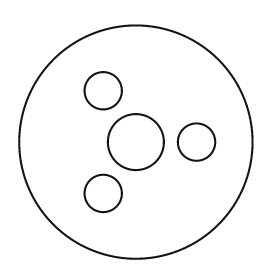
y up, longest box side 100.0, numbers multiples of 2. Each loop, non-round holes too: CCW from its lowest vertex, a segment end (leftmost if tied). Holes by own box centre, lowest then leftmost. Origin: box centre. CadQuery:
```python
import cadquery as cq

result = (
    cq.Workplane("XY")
    .moveTo(0.0, 0.0)
    .circle(50.0)
    .moveTo(-14.0, -22.0)
    .circle(8.0)
    .moveTo(0.0, 0.0)
    .circle(12.0)
    .moveTo(26.0, 0.0)
    .circle(8.0)
    .moveTo(-14.0, 22.0)
    .circle(8.0)
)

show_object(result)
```